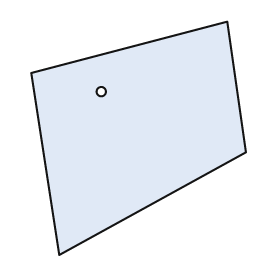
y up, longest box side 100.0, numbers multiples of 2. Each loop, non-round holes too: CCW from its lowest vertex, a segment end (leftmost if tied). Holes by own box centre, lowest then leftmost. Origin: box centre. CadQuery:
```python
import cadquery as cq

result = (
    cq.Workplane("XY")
    .moveTo(-34.0, -50.0)
    .lineTo(46.0, -6.0)
    .lineTo(38.0, 50.0)
    .lineTo(-46.0, 28.0)
    .close()
    .moveTo(-16.0, 20.0)
    .circle(2.0)
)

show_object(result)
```